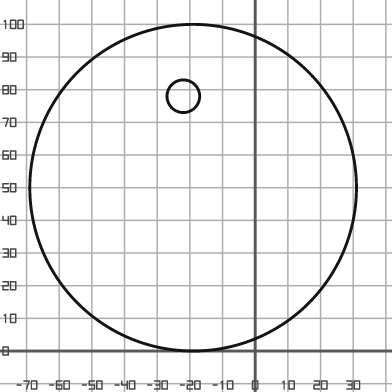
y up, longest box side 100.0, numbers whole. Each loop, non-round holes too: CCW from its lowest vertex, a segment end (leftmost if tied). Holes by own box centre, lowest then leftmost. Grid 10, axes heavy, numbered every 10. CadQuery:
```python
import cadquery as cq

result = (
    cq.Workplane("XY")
    .moveTo(-19.0, 50.0)
    .circle(50.0)
    .moveTo(-22.0, 78.0)
    .circle(5.0)
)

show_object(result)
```